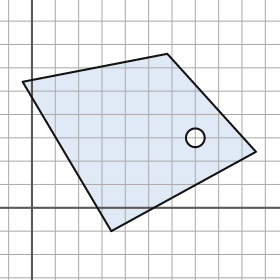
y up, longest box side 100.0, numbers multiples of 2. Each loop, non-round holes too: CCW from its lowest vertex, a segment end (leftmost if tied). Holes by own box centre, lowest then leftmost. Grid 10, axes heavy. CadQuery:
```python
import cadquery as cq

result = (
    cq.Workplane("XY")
    .moveTo(34.0, -10.0)
    .lineTo(96.0, 24.0)
    .lineTo(58.0, 66.0)
    .lineTo(-4.0, 54.0)
    .close()
    .moveTo(70.0, 30.0)
    .circle(4.0)
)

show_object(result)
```